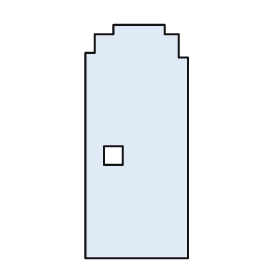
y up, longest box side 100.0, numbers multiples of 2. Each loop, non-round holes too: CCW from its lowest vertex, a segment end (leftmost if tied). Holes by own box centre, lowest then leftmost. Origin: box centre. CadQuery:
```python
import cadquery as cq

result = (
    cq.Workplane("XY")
    .moveTo(-22.0, -50.0)
    .lineTo(22.0, -50.0)
    .lineTo(22.0, 36.0)
    .lineTo(18.0, 36.0)
    .lineTo(18.0, 46.0)
    .lineTo(12.0, 46.0)
    .lineTo(12.0, 50.0)
    .lineTo(-10.0, 50.0)
    .lineTo(-10.0, 46.0)
    .lineTo(-18.0, 46.0)
    .lineTo(-18.0, 38.0)
    .lineTo(-22.0, 38.0)
    .close()
    .moveTo(-14.0, -10.0)
    .lineTo(-6.0, -10.0)
    .lineTo(-6.0, -2.0)
    .lineTo(-14.0, -2.0)
    .close()
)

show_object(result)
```